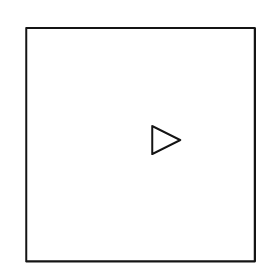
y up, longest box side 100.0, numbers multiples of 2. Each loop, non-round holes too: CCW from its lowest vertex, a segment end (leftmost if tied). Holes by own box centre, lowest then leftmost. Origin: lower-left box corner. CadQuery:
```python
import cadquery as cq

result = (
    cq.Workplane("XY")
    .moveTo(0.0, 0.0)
    .lineTo(98.0, 0.0)
    .lineTo(98.0, 100.0)
    .lineTo(0.0, 100.0)
    .close()
    .moveTo(54.0, 46.0)
    .lineTo(66.0, 52.0)
    .lineTo(54.0, 58.0)
    .close()
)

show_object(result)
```